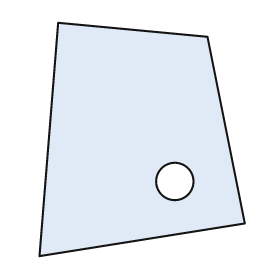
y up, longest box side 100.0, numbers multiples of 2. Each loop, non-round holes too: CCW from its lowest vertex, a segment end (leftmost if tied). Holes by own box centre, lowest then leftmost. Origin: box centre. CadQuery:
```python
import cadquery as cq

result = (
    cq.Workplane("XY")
    .moveTo(-44.0, -50.0)
    .lineTo(44.0, -36.0)
    .lineTo(28.0, 44.0)
    .lineTo(-36.0, 50.0)
    .close()
    .moveTo(14.0, -18.0)
    .circle(8.0)
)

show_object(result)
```